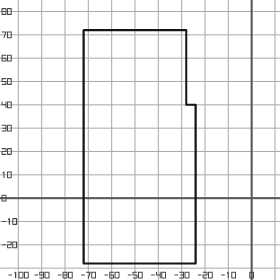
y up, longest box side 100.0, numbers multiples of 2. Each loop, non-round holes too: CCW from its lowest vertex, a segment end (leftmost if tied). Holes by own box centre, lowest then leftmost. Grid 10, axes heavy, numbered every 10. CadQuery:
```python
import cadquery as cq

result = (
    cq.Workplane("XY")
    .moveTo(-72.0, -28.0)
    .lineTo(-24.0, -28.0)
    .lineTo(-24.0, 40.0)
    .lineTo(-28.0, 40.0)
    .lineTo(-28.0, 72.0)
    .lineTo(-72.0, 72.0)
    .close()
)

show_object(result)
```